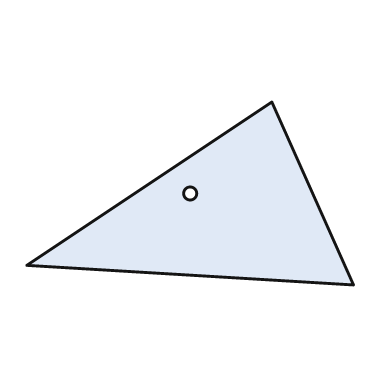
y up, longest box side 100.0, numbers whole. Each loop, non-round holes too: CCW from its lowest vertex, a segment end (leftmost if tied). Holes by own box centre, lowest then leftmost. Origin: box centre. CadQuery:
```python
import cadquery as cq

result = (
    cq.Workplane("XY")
    .moveTo(50.0, -28.0)
    .lineTo(25.0, 28.0)
    .lineTo(-50.0, -22.0)
    .close()
    .moveTo(0.0, 0.0)
    .circle(2.0)
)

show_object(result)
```